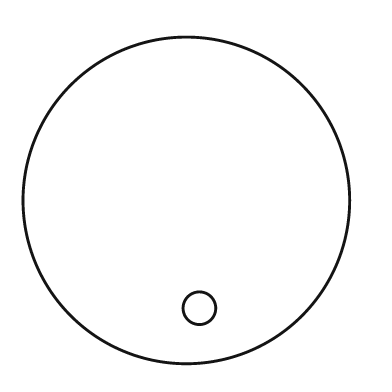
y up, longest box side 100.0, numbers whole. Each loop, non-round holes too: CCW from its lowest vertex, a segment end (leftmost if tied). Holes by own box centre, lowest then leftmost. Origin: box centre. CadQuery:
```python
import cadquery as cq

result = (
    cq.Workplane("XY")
    .moveTo(0.0, 0.0)
    .circle(50.0)
    .moveTo(4.0, -33.0)
    .circle(5.0)
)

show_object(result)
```